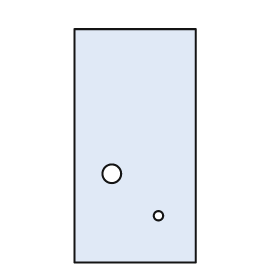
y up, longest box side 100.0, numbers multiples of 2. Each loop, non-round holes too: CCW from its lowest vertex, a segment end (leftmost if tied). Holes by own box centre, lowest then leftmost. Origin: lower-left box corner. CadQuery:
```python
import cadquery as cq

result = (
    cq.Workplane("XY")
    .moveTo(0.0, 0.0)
    .lineTo(52.0, 0.0)
    .lineTo(52.0, 100.0)
    .lineTo(0.0, 100.0)
    .close()
    .moveTo(36.0, 20.0)
    .circle(2.0)
    .moveTo(16.0, 38.0)
    .circle(4.0)
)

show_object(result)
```